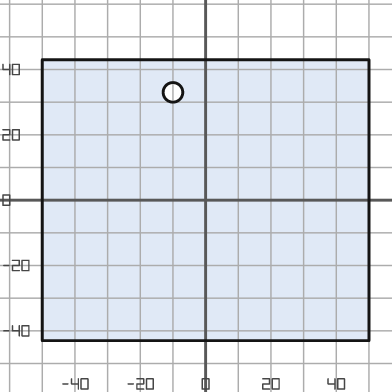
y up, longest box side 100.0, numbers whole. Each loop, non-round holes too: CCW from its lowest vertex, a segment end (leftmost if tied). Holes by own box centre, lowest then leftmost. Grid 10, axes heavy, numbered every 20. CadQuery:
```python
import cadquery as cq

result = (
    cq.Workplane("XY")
    .moveTo(-50.0, -43.0)
    .lineTo(50.0, -43.0)
    .lineTo(50.0, 43.0)
    .lineTo(-50.0, 43.0)
    .close()
    .moveTo(-10.0, 33.0)
    .circle(3.0)
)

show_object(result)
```